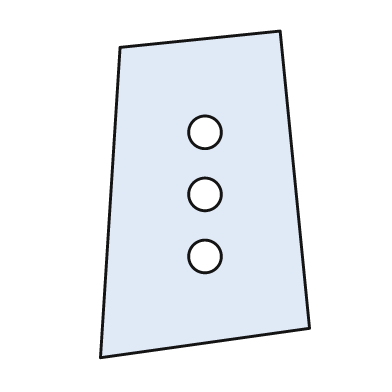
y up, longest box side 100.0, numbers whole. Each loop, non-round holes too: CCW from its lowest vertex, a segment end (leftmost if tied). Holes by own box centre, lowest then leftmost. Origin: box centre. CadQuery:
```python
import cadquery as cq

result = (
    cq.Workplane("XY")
    .moveTo(-32.0, -50.0)
    .lineTo(32.0, -41.0)
    .lineTo(23.0, 50.0)
    .lineTo(-26.0, 45.0)
    .close()
    .moveTo(0.0, -19.0)
    .circle(5.0)
    .moveTo(0.0, 0.0)
    .circle(5.0)
    .moveTo(0.0, 19.0)
    .circle(5.0)
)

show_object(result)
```